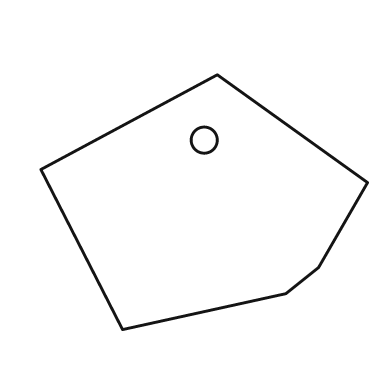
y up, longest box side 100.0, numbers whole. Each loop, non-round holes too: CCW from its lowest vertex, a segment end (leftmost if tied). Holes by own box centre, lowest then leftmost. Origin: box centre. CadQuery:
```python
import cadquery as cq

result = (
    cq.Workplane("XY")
    .moveTo(-25.0, -39.0)
    .lineTo(25.0, -28.0)
    .lineTo(35.0, -20.0)
    .lineTo(50.0, 6.0)
    .lineTo(4.0, 39.0)
    .lineTo(-50.0, 10.0)
    .close()
    .moveTo(0.0, 19.0)
    .circle(4.0)
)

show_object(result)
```